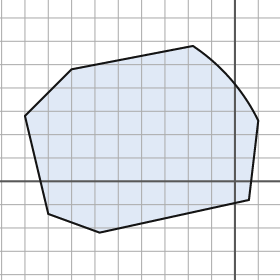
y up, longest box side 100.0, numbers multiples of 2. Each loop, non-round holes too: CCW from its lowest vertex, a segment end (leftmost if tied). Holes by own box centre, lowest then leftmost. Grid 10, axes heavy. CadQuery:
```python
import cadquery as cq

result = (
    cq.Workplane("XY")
    .moveTo(-58.0, -22.0)
    .lineTo(6.0, -8.0)
    .lineTo(10.0, 26.0)
    .threePointArc((-2.0, 44.0), (-18.0, 58.0))
    .lineTo(-70.0, 48.0)
    .lineTo(-90.0, 28.0)
    .lineTo(-80.0, -14.0)
    .close()
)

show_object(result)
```